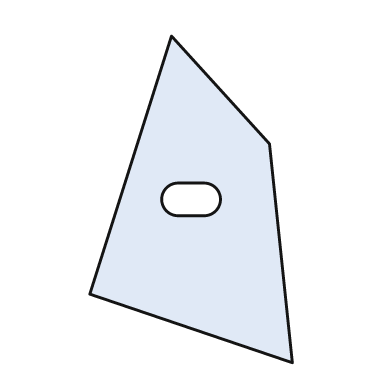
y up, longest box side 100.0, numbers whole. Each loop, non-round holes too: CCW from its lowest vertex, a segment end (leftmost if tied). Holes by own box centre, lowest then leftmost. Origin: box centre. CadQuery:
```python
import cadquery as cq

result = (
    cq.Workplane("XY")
    .moveTo(31.0, -50.0)
    .lineTo(24.0, 17.0)
    .lineTo(-6.0, 50.0)
    .lineTo(-31.0, -29.0)
    .close()
    .moveTo(-4.0, -5.0)
    .lineTo(4.0, -5.0)
    .threePointArc((9.0, 0.0), (4.0, 5.0))
    .lineTo(-4.0, 5.0)
    .threePointArc((-9.0, 0.0), (-4.0, -5.0))
    .close()
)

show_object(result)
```